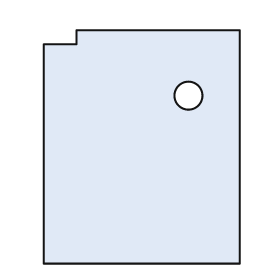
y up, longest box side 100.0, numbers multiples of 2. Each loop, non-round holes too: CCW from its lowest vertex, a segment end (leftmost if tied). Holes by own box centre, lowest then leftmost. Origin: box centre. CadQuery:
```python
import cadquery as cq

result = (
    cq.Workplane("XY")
    .moveTo(-42.0, -50.0)
    .lineTo(42.0, -50.0)
    .lineTo(42.0, 50.0)
    .lineTo(-28.0, 50.0)
    .lineTo(-28.0, 44.0)
    .lineTo(-42.0, 44.0)
    .close()
    .moveTo(20.0, 22.0)
    .circle(6.0)
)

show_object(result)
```